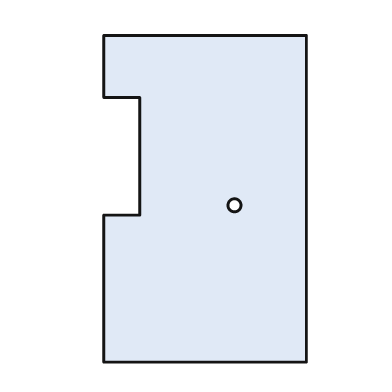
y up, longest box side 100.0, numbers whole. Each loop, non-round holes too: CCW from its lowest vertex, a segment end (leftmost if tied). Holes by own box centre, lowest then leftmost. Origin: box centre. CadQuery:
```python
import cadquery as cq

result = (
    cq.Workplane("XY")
    .moveTo(-31.0, -50.0)
    .lineTo(31.0, -50.0)
    .lineTo(31.0, 50.0)
    .lineTo(-31.0, 50.0)
    .lineTo(-31.0, 31.0)
    .lineTo(-20.0, 31.0)
    .lineTo(-20.0, -5.0)
    .lineTo(-31.0, -5.0)
    .close()
    .moveTo(9.0, -2.0)
    .circle(2.0)
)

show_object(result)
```